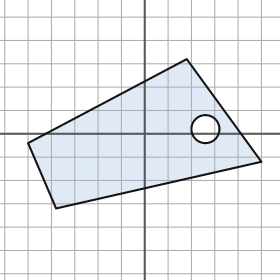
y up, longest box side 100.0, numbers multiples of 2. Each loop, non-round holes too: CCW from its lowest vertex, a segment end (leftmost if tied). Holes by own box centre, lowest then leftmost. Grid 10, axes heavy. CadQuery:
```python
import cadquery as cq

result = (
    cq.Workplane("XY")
    .moveTo(-38.0, -32.0)
    .lineTo(50.0, -12.0)
    .lineTo(18.0, 32.0)
    .lineTo(-50.0, -4.0)
    .close()
    .moveTo(26.0, 2.0)
    .circle(6.0)
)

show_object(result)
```